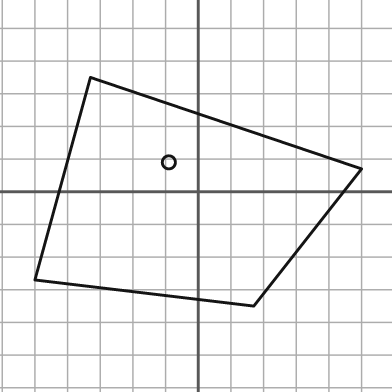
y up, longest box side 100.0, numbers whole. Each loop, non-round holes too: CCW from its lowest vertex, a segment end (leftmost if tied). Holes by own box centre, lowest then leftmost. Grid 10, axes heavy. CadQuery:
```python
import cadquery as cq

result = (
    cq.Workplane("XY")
    .moveTo(17.0, -35.0)
    .lineTo(50.0, 7.0)
    .lineTo(-33.0, 35.0)
    .lineTo(-50.0, -27.0)
    .close()
    .moveTo(-9.0, 9.0)
    .circle(2.0)
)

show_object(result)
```